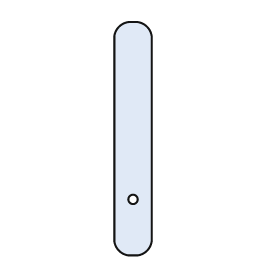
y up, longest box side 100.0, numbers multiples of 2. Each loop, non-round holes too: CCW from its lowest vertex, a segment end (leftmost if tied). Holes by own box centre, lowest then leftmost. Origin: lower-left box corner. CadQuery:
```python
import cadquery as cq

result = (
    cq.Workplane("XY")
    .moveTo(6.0, 0.0)
    .lineTo(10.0, 0.0)
    .threePointArc((14.0, 2.0), (16.0, 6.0))
    .lineTo(16.0, 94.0)
    .threePointArc((14.0, 98.0), (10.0, 100.0))
    .lineTo(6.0, 100.0)
    .threePointArc((2.0, 98.0), (0.0, 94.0))
    .lineTo(0.0, 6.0)
    .threePointArc((2.0, 2.0), (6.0, 0.0))
    .close()
    .moveTo(8.0, 24.0)
    .circle(2.0)
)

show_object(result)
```